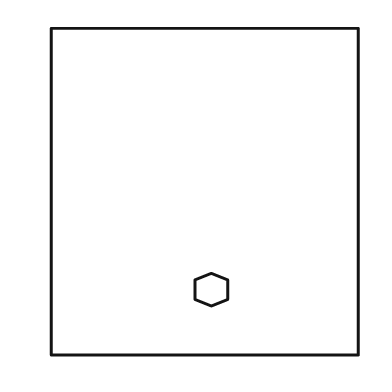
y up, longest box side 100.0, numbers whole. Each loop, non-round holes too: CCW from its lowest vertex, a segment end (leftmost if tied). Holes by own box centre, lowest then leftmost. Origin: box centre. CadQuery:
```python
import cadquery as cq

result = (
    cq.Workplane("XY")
    .moveTo(-47.0, -50.0)
    .lineTo(47.0, -50.0)
    .lineTo(47.0, 50.0)
    .lineTo(-47.0, 50.0)
    .close()
    .moveTo(2.0, -35.0)
    .lineTo(7.0, -33.0)
    .lineTo(7.0, -27.0)
    .lineTo(2.0, -25.0)
    .lineTo(-3.0, -27.0)
    .lineTo(-3.0, -33.0)
    .close()
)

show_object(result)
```